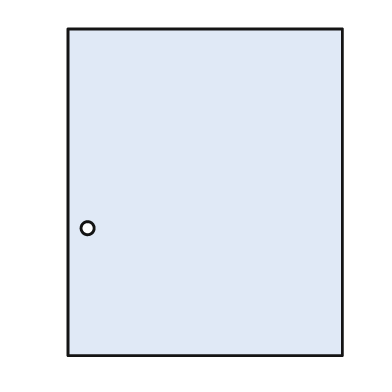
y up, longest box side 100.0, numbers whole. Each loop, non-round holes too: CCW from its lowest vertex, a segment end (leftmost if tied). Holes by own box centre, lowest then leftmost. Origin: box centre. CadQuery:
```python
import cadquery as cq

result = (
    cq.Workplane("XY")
    .moveTo(-42.0, -50.0)
    .lineTo(42.0, -50.0)
    .lineTo(42.0, 50.0)
    .lineTo(-42.0, 50.0)
    .close()
    .moveTo(-36.0, -11.0)
    .circle(2.0)
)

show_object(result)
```